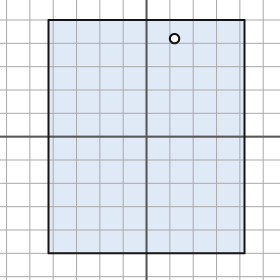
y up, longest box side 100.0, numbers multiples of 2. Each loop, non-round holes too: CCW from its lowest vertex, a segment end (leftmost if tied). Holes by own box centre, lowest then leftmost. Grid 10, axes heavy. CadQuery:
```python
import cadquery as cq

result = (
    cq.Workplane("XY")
    .moveTo(-42.0, -50.0)
    .lineTo(42.0, -50.0)
    .lineTo(42.0, 50.0)
    .lineTo(-42.0, 50.0)
    .close()
    .moveTo(12.0, 42.0)
    .circle(2.0)
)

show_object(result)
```